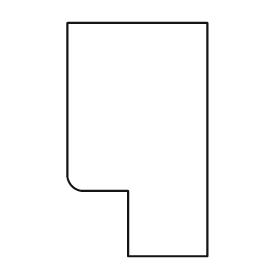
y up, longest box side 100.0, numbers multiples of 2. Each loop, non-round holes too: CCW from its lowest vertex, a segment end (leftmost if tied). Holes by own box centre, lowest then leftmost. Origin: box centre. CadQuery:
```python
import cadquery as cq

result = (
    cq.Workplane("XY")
    .moveTo(-4.0, -50.0)
    .lineTo(30.0, -50.0)
    .lineTo(30.0, 50.0)
    .lineTo(-30.0, 50.0)
    .lineTo(-30.0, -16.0)
    .threePointArc((-28.0, -20.0), (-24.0, -22.0))
    .lineTo(-4.0, -22.0)
    .close()
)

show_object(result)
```